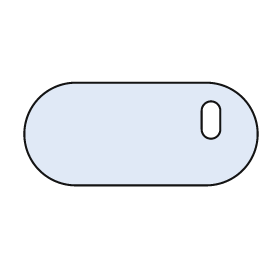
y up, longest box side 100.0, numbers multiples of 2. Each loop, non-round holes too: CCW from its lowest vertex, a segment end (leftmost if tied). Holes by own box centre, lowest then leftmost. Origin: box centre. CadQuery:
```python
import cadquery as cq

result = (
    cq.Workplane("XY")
    .moveTo(-28.0, -22.0)
    .lineTo(28.0, -22.0)
    .threePointArc((50.0, 0.0), (28.0, 22.0))
    .lineTo(-28.0, 22.0)
    .threePointArc((-50.0, 0.0), (-28.0, -22.0))
    .close()
    .moveTo(26.0, 2.0)
    .threePointArc((30.0, -2.0), (34.0, 2.0))
    .lineTo(34.0, 10.0)
    .threePointArc((30.0, 14.0), (26.0, 10.0))
    .close()
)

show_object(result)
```